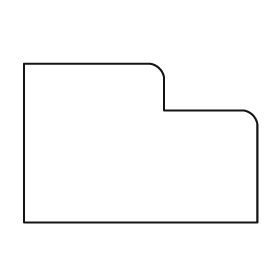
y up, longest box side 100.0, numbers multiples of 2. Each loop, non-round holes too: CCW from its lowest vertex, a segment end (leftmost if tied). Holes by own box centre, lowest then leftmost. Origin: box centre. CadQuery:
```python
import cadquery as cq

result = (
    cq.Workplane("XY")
    .moveTo(-50.0, -34.0)
    .lineTo(50.0, -34.0)
    .lineTo(50.0, 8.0)
    .threePointArc((48.0, 12.0), (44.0, 14.0))
    .lineTo(10.0, 14.0)
    .lineTo(10.0, 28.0)
    .threePointArc((8.0, 32.0), (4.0, 34.0))
    .lineTo(-50.0, 34.0)
    .close()
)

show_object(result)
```